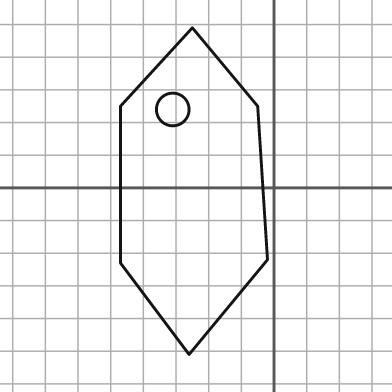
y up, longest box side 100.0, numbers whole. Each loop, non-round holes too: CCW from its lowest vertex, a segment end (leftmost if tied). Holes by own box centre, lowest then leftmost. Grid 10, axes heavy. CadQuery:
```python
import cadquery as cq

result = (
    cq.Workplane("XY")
    .moveTo(-26.0, -51.0)
    .lineTo(-2.0, -22.0)
    .lineTo(-5.0, 25.0)
    .lineTo(-25.0, 49.0)
    .lineTo(-47.0, 25.0)
    .lineTo(-47.0, -23.0)
    .close()
    .moveTo(-31.0, 24.0)
    .circle(5.0)
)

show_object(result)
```